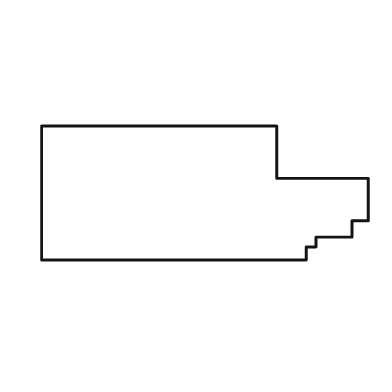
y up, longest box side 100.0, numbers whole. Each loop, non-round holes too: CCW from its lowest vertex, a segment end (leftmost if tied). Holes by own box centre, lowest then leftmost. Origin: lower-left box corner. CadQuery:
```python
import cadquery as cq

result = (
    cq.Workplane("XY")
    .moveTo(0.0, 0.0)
    .lineTo(81.0, 0.0)
    .lineTo(81.0, 4.0)
    .lineTo(84.0, 4.0)
    .lineTo(84.0, 7.0)
    .lineTo(95.0, 7.0)
    .lineTo(95.0, 12.0)
    .lineTo(100.0, 12.0)
    .lineTo(100.0, 25.0)
    .lineTo(72.0, 25.0)
    .lineTo(72.0, 41.0)
    .lineTo(0.0, 41.0)
    .close()
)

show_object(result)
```